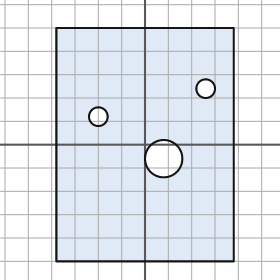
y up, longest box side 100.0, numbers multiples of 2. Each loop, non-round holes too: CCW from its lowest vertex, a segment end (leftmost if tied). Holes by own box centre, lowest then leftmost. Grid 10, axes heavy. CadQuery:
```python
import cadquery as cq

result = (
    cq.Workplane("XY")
    .moveTo(-38.0, -50.0)
    .lineTo(38.0, -50.0)
    .lineTo(38.0, 50.0)
    .lineTo(-38.0, 50.0)
    .close()
    .moveTo(8.0, -6.0)
    .circle(8.0)
    .moveTo(-20.0, 12.0)
    .circle(4.0)
    .moveTo(26.0, 24.0)
    .circle(4.0)
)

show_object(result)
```